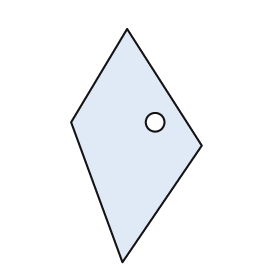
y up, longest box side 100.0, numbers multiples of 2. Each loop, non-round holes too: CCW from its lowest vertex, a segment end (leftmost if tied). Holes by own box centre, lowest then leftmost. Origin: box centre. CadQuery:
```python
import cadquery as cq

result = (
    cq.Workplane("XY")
    .moveTo(-6.0, -50.0)
    .lineTo(28.0, 0.0)
    .lineTo(-4.0, 50.0)
    .lineTo(-28.0, 10.0)
    .close()
    .moveTo(8.0, 10.0)
    .circle(4.0)
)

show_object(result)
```